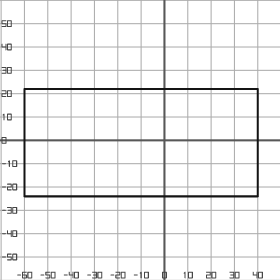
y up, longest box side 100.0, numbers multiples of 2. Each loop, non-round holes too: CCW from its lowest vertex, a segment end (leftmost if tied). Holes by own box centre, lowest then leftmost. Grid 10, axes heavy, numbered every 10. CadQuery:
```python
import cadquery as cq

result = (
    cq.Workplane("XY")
    .moveTo(-60.0, -24.0)
    .lineTo(40.0, -24.0)
    .lineTo(40.0, 22.0)
    .lineTo(-60.0, 22.0)
    .close()
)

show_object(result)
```